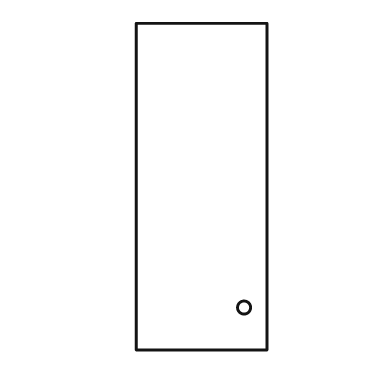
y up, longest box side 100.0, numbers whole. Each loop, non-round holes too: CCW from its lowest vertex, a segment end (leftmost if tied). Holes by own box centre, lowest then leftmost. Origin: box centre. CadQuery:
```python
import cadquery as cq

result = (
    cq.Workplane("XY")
    .moveTo(-20.0, -50.0)
    .lineTo(20.0, -50.0)
    .lineTo(20.0, 50.0)
    .lineTo(-20.0, 50.0)
    .close()
    .moveTo(13.0, -37.0)
    .circle(2.0)
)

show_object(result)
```